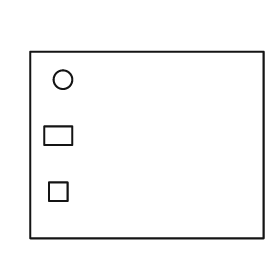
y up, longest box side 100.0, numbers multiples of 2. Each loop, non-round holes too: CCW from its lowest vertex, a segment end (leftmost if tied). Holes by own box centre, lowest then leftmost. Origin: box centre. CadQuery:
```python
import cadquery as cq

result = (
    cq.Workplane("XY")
    .moveTo(-50.0, -40.0)
    .lineTo(50.0, -40.0)
    .lineTo(50.0, 40.0)
    .lineTo(-50.0, 40.0)
    .close()
    .moveTo(-42.0, -24.0)
    .lineTo(-34.0, -24.0)
    .lineTo(-34.0, -16.0)
    .lineTo(-42.0, -16.0)
    .close()
    .moveTo(-44.0, 0.0)
    .lineTo(-32.0, 0.0)
    .lineTo(-32.0, 8.0)
    .lineTo(-44.0, 8.0)
    .close()
    .moveTo(-36.0, 28.0)
    .circle(4.0)
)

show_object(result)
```